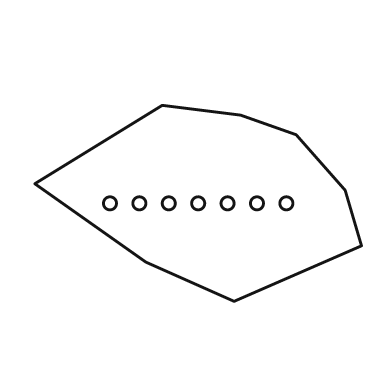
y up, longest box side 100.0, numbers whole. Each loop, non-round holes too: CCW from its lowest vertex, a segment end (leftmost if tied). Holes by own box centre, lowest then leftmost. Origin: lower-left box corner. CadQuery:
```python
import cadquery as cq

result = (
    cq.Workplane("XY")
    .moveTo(61.0, 0.0)
    .lineTo(100.0, 17.0)
    .lineTo(95.0, 34.0)
    .lineTo(80.0, 51.0)
    .lineTo(63.0, 57.0)
    .lineTo(39.0, 60.0)
    .lineTo(0.0, 36.0)
    .lineTo(34.0, 12.0)
    .close()
    .moveTo(23.0, 30.0)
    .circle(2.0)
    .moveTo(32.0, 30.0)
    .circle(2.0)
    .moveTo(41.0, 30.0)
    .circle(2.0)
    .moveTo(50.0, 30.0)
    .circle(2.0)
    .moveTo(59.0, 30.0)
    .circle(2.0)
    .moveTo(68.0, 30.0)
    .circle(2.0)
    .moveTo(77.0, 30.0)
    .circle(2.0)
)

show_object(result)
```